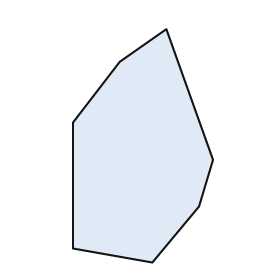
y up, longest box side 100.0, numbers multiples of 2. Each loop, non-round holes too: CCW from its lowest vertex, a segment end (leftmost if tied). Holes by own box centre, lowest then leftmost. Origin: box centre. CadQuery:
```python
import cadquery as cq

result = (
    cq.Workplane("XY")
    .moveTo(4.0, -50.0)
    .lineTo(24.0, -26.0)
    .lineTo(30.0, -6.0)
    .lineTo(10.0, 50.0)
    .lineTo(-10.0, 36.0)
    .lineTo(-30.0, 10.0)
    .lineTo(-30.0, -44.0)
    .close()
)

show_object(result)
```